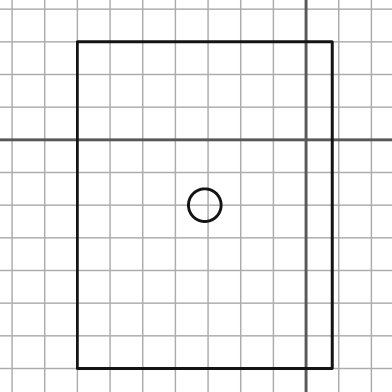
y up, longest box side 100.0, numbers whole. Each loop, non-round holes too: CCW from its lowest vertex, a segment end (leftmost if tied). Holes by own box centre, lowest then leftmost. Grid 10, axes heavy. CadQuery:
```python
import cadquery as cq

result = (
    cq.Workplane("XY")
    .moveTo(-70.0, -70.0)
    .lineTo(8.0, -70.0)
    .lineTo(8.0, 30.0)
    .lineTo(-70.0, 30.0)
    .close()
    .moveTo(-31.0, -20.0)
    .circle(5.0)
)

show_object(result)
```